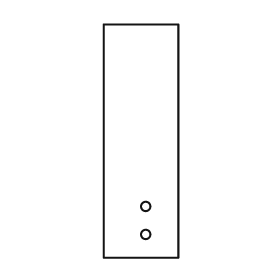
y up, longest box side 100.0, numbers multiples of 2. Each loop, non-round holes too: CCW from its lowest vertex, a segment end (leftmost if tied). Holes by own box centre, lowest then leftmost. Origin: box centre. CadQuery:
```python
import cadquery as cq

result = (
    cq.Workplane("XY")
    .moveTo(-16.0, -50.0)
    .lineTo(16.0, -50.0)
    .lineTo(16.0, 50.0)
    .lineTo(-16.0, 50.0)
    .close()
    .moveTo(2.0, -40.0)
    .circle(2.0)
    .moveTo(2.0, -28.0)
    .circle(2.0)
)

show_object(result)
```